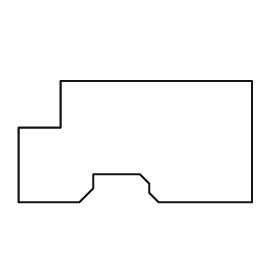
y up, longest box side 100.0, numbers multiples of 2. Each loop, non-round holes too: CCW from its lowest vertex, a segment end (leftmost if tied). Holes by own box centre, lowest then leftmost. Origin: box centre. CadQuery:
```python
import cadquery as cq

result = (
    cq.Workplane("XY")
    .moveTo(-50.0, -26.0)
    .lineTo(-24.0, -26.0)
    .lineTo(-18.0, -20.0)
    .lineTo(-18.0, -14.0)
    .lineTo(2.0, -14.0)
    .lineTo(6.0, -18.0)
    .lineTo(6.0, -22.0)
    .lineTo(10.0, -26.0)
    .lineTo(50.0, -26.0)
    .lineTo(50.0, 26.0)
    .lineTo(-32.0, 26.0)
    .lineTo(-32.0, 6.0)
    .lineTo(-50.0, 6.0)
    .close()
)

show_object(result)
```